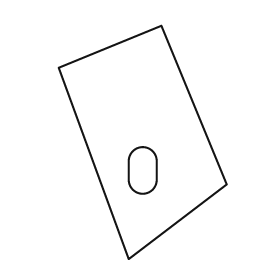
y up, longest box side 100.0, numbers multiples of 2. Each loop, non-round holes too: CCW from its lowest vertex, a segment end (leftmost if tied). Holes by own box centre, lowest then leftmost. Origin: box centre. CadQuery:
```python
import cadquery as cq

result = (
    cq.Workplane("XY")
    .moveTo(-6.0, -50.0)
    .lineTo(36.0, -18.0)
    .lineTo(8.0, 50.0)
    .lineTo(-36.0, 32.0)
    .close()
    .moveTo(-6.0, -16.0)
    .threePointArc((0.0, -22.0), (6.0, -16.0))
    .lineTo(6.0, -8.0)
    .threePointArc((0.0, -2.0), (-6.0, -8.0))
    .close()
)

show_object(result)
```